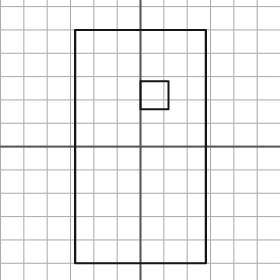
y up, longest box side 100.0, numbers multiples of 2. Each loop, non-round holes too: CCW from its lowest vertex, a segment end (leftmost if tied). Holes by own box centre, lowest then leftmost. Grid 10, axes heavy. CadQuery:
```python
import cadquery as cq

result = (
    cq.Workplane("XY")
    .moveTo(-28.0, -50.0)
    .lineTo(28.0, -50.0)
    .lineTo(28.0, 50.0)
    .lineTo(-28.0, 50.0)
    .close()
    .moveTo(0.0, 16.0)
    .lineTo(12.0, 16.0)
    .lineTo(12.0, 28.0)
    .lineTo(0.0, 28.0)
    .close()
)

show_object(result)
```